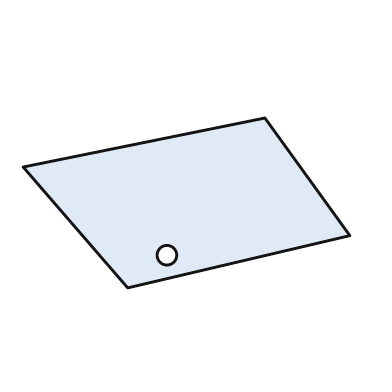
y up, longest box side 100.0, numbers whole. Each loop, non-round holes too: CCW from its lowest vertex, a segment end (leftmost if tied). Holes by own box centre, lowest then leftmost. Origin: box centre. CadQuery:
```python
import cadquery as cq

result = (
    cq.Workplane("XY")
    .moveTo(-18.0, -26.0)
    .lineTo(50.0, -10.0)
    .lineTo(24.0, 26.0)
    .lineTo(-50.0, 11.0)
    .close()
    .moveTo(-6.0, -16.0)
    .circle(3.0)
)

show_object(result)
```